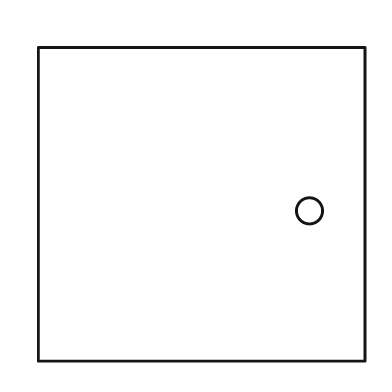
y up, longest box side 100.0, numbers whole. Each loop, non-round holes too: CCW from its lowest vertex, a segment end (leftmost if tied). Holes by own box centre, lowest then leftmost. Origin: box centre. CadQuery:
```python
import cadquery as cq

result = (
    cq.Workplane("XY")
    .moveTo(-50.0, -48.0)
    .lineTo(50.0, -48.0)
    .lineTo(50.0, 48.0)
    .lineTo(-50.0, 48.0)
    .close()
    .moveTo(33.0, -2.0)
    .circle(4.0)
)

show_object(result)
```